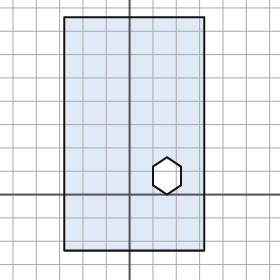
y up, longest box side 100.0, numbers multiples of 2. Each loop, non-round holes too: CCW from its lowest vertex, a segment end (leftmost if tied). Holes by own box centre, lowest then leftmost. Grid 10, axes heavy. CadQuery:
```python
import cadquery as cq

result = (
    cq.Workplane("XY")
    .moveTo(-28.0, -24.0)
    .lineTo(32.0, -24.0)
    .lineTo(32.0, 76.0)
    .lineTo(-28.0, 76.0)
    .close()
    .moveTo(16.0, 0.0)
    .lineTo(22.0, 4.0)
    .lineTo(22.0, 12.0)
    .lineTo(16.0, 16.0)
    .lineTo(10.0, 12.0)
    .lineTo(10.0, 4.0)
    .close()
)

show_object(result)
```